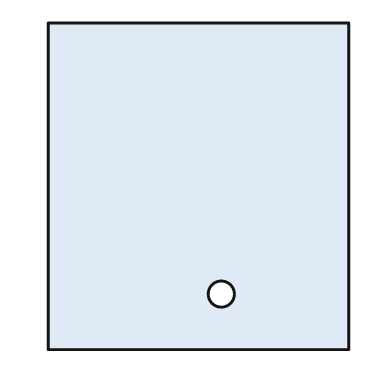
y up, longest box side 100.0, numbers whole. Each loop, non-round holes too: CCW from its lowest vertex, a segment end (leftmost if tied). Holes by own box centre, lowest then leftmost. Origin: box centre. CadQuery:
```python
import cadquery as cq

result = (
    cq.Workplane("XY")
    .moveTo(-46.0, -50.0)
    .lineTo(46.0, -50.0)
    .lineTo(46.0, 50.0)
    .lineTo(-46.0, 50.0)
    .close()
    .moveTo(7.0, -33.0)
    .circle(4.0)
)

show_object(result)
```